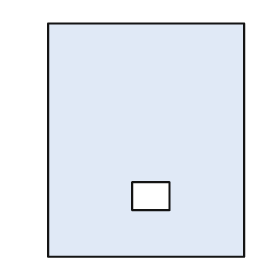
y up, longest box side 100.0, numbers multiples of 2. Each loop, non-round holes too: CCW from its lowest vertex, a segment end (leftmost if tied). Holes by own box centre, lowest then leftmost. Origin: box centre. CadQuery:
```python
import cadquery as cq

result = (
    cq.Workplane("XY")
    .moveTo(-42.0, -50.0)
    .lineTo(42.0, -50.0)
    .lineTo(42.0, 50.0)
    .lineTo(-42.0, 50.0)
    .close()
    .moveTo(-6.0, -30.0)
    .lineTo(10.0, -30.0)
    .lineTo(10.0, -18.0)
    .lineTo(-6.0, -18.0)
    .close()
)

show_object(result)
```